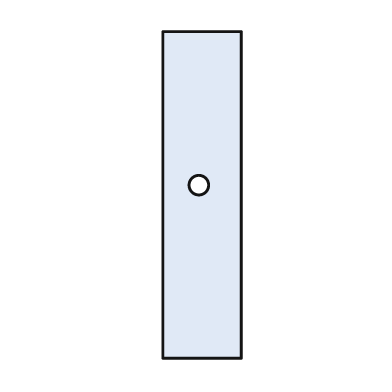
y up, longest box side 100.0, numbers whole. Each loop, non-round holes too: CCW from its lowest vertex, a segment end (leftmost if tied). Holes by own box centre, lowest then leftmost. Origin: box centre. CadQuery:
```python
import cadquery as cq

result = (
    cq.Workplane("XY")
    .moveTo(-12.0, -50.0)
    .lineTo(12.0, -50.0)
    .lineTo(12.0, 50.0)
    .lineTo(-12.0, 50.0)
    .close()
    .moveTo(-1.0, 3.0)
    .circle(3.0)
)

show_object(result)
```